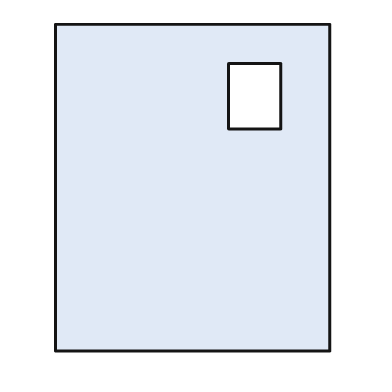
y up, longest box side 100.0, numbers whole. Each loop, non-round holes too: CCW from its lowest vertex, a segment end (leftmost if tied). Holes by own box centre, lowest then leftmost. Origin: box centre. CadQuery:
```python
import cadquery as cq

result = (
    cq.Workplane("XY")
    .moveTo(-42.0, -50.0)
    .lineTo(42.0, -50.0)
    .lineTo(42.0, 50.0)
    .lineTo(-42.0, 50.0)
    .close()
    .moveTo(11.0, 18.0)
    .lineTo(27.0, 18.0)
    .lineTo(27.0, 38.0)
    .lineTo(11.0, 38.0)
    .close()
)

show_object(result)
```